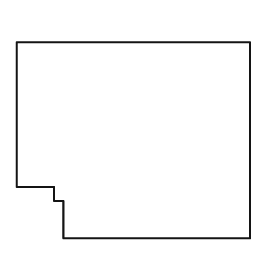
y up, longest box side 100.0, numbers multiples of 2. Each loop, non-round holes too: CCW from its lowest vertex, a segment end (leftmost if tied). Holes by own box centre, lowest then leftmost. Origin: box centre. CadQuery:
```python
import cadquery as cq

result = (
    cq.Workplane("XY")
    .moveTo(-30.0, -42.0)
    .lineTo(50.0, -42.0)
    .lineTo(50.0, 42.0)
    .lineTo(-50.0, 42.0)
    .lineTo(-50.0, -20.0)
    .lineTo(-34.0, -20.0)
    .lineTo(-34.0, -26.0)
    .lineTo(-30.0, -26.0)
    .close()
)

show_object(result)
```